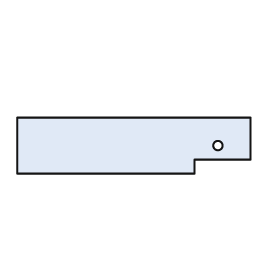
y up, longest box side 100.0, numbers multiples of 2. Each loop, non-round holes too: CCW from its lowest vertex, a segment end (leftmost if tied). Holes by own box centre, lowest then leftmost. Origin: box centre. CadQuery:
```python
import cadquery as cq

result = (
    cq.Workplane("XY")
    .moveTo(-50.0, -12.0)
    .lineTo(26.0, -12.0)
    .lineTo(26.0, -6.0)
    .lineTo(50.0, -6.0)
    .lineTo(50.0, 12.0)
    .lineTo(-50.0, 12.0)
    .close()
    .moveTo(36.0, 0.0)
    .circle(2.0)
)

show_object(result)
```